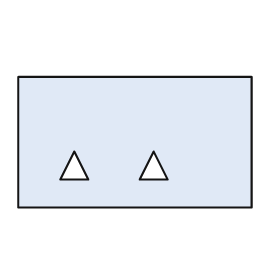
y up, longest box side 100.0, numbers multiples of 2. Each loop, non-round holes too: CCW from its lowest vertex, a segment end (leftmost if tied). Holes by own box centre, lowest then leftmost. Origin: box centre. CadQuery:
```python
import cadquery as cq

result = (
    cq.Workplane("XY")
    .moveTo(-50.0, -28.0)
    .lineTo(50.0, -28.0)
    .lineTo(50.0, 28.0)
    .lineTo(-50.0, 28.0)
    .close()
    .moveTo(-32.0, -16.0)
    .lineTo(-20.0, -16.0)
    .lineTo(-26.0, -4.0)
    .close()
    .moveTo(2.0, -16.0)
    .lineTo(14.0, -16.0)
    .lineTo(8.0, -4.0)
    .close()
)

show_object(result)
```